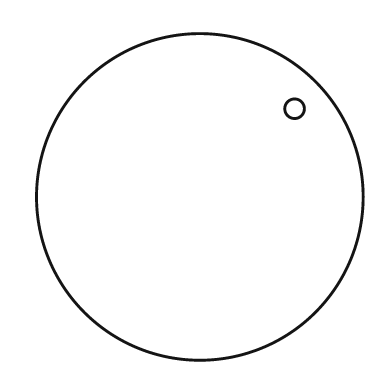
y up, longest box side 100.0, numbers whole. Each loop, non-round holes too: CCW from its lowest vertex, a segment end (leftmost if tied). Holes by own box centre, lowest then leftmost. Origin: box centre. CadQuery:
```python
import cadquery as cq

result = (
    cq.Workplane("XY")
    .moveTo(0.0, 0.0)
    .circle(50.0)
    .moveTo(29.0, 27.0)
    .circle(3.0)
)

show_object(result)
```